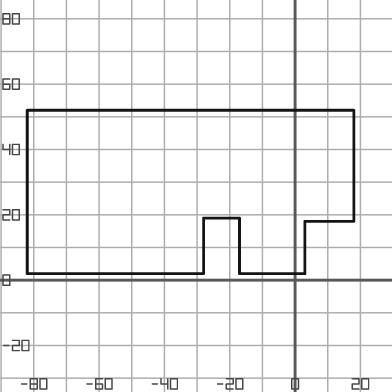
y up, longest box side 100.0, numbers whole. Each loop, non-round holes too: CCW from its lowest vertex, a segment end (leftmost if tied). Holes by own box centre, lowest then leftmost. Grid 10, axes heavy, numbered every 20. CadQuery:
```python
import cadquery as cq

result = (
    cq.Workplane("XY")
    .moveTo(-82.0, 2.0)
    .lineTo(-28.0, 2.0)
    .lineTo(-28.0, 19.0)
    .lineTo(-17.0, 19.0)
    .lineTo(-17.0, 2.0)
    .lineTo(3.0, 2.0)
    .lineTo(3.0, 18.0)
    .lineTo(18.0, 18.0)
    .lineTo(18.0, 52.0)
    .lineTo(-82.0, 52.0)
    .close()
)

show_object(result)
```